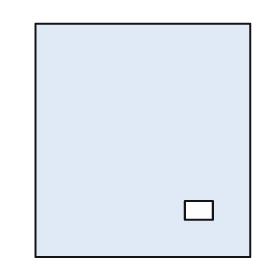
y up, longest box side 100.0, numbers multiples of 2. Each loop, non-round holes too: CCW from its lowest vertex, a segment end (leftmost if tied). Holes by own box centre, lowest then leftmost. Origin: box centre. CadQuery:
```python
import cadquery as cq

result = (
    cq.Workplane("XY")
    .moveTo(-46.0, -50.0)
    .lineTo(46.0, -50.0)
    .lineTo(46.0, 50.0)
    .lineTo(-46.0, 50.0)
    .close()
    .moveTo(18.0, -34.0)
    .lineTo(30.0, -34.0)
    .lineTo(30.0, -26.0)
    .lineTo(18.0, -26.0)
    .close()
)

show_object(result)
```